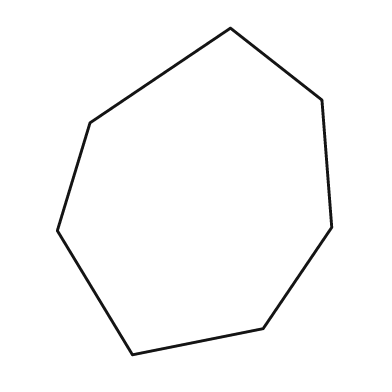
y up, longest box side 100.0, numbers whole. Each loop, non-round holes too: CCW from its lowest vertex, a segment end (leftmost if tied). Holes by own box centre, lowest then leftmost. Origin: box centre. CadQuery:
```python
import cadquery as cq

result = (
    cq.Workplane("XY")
    .moveTo(-19.0, -50.0)
    .lineTo(21.0, -42.0)
    .lineTo(42.0, -11.0)
    .lineTo(39.0, 28.0)
    .lineTo(11.0, 50.0)
    .lineTo(-32.0, 21.0)
    .lineTo(-42.0, -12.0)
    .close()
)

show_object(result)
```